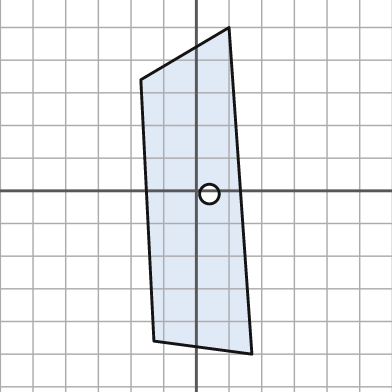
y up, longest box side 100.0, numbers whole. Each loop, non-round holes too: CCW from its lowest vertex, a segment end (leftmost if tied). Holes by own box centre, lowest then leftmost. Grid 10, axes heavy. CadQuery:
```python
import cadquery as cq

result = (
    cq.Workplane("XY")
    .moveTo(17.0, -50.0)
    .lineTo(10.0, 50.0)
    .lineTo(-17.0, 34.0)
    .lineTo(-13.0, -46.0)
    .close()
    .moveTo(4.0, -1.0)
    .circle(3.0)
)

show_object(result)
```